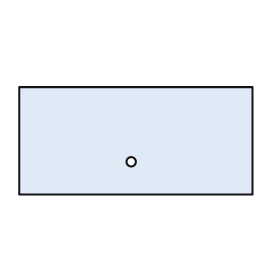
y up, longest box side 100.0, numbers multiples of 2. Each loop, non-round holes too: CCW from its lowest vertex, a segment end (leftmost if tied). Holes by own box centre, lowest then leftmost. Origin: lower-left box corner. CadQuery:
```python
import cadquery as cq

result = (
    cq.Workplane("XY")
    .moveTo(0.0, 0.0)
    .lineTo(100.0, 0.0)
    .lineTo(100.0, 46.0)
    .lineTo(0.0, 46.0)
    .close()
    .moveTo(48.0, 14.0)
    .circle(2.0)
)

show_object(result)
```